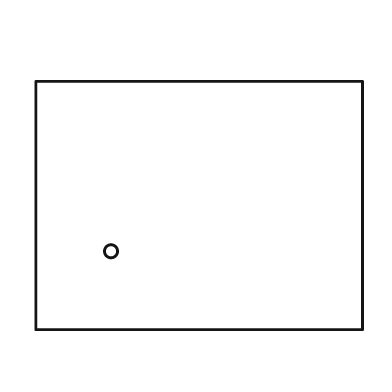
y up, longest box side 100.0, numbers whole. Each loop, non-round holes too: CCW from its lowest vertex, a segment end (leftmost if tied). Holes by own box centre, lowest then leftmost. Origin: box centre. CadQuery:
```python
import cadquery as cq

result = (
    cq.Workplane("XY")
    .moveTo(-50.0, -38.0)
    .lineTo(50.0, -38.0)
    .lineTo(50.0, 38.0)
    .lineTo(-50.0, 38.0)
    .close()
    .moveTo(-27.0, -14.0)
    .circle(2.0)
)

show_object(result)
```